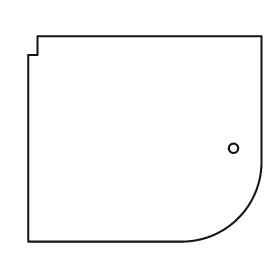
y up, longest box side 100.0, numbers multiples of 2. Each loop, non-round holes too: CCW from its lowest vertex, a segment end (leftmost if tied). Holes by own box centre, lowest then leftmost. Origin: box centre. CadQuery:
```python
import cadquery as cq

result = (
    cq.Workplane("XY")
    .moveTo(-50.0, -44.0)
    .lineTo(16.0, -44.0)
    .threePointArc((40.0, -34.0), (50.0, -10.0))
    .lineTo(50.0, 44.0)
    .lineTo(-46.0, 44.0)
    .lineTo(-46.0, 36.0)
    .lineTo(-50.0, 36.0)
    .close()
    .moveTo(38.0, -4.0)
    .circle(2.0)
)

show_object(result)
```